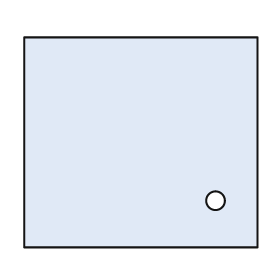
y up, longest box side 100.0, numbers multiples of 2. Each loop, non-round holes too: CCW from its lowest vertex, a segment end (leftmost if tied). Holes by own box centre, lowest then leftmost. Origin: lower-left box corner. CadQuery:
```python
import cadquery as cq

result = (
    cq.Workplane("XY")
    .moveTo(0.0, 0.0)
    .lineTo(100.0, 0.0)
    .lineTo(100.0, 90.0)
    .lineTo(0.0, 90.0)
    .close()
    .moveTo(82.0, 20.0)
    .circle(4.0)
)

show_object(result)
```